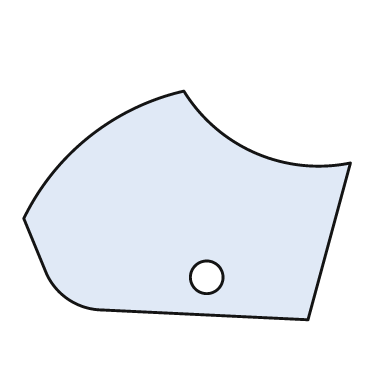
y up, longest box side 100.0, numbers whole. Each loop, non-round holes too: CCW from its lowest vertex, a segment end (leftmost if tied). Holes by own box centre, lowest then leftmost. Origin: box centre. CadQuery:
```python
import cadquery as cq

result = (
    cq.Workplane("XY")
    .moveTo(37.0, -35.0)
    .lineTo(50.0, 13.0)
    .threePointArc((21.0, 16.0), (-1.0, 35.0))
    .threePointArc((-30.0, 21.0), (-50.0, -4.0))
    .lineTo(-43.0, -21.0)
    .threePointArc((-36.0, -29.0), (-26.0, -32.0))
    .close()
    .moveTo(6.0, -22.0)
    .circle(5.0)
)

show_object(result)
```